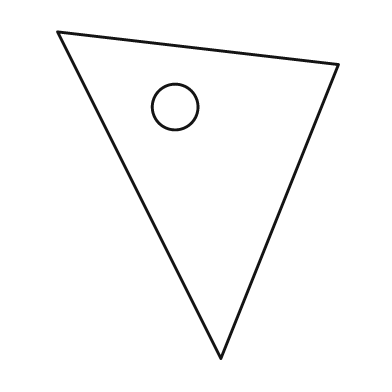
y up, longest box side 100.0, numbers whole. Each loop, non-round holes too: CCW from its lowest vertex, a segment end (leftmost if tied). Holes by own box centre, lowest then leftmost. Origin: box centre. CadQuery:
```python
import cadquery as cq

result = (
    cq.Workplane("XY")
    .moveTo(7.0, -50.0)
    .lineTo(43.0, 40.0)
    .lineTo(-43.0, 50.0)
    .close()
    .moveTo(-7.0, 27.0)
    .circle(7.0)
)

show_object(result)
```